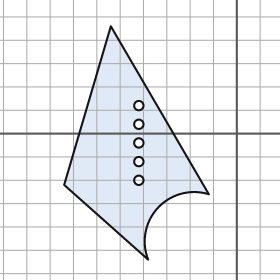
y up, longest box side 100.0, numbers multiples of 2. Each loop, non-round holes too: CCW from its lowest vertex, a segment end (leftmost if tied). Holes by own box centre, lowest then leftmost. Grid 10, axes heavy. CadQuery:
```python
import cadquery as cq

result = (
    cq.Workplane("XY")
    .moveTo(-38.0, -54.0)
    .threePointArc((-34.0, -32.0), (-12.0, -26.0))
    .lineTo(-54.0, 46.0)
    .lineTo(-74.0, -22.0)
    .close()
    .moveTo(-42.0, -20.0)
    .circle(2.0)
    .moveTo(-42.0, -12.0)
    .circle(2.0)
    .moveTo(-42.0, -4.0)
    .circle(2.0)
    .moveTo(-42.0, 4.0)
    .circle(2.0)
    .moveTo(-42.0, 12.0)
    .circle(2.0)
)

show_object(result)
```